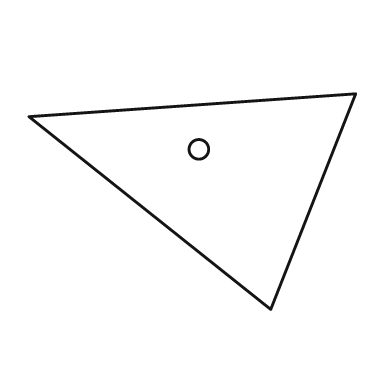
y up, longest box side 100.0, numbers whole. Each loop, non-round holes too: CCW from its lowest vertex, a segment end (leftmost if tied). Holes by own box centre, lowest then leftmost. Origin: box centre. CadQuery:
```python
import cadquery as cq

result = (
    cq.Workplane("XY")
    .moveTo(24.0, -33.0)
    .lineTo(50.0, 33.0)
    .lineTo(-50.0, 26.0)
    .close()
    .moveTo(2.0, 16.0)
    .circle(3.0)
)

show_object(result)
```